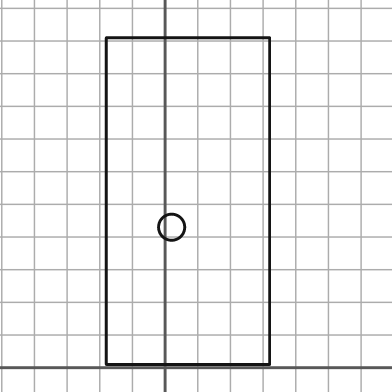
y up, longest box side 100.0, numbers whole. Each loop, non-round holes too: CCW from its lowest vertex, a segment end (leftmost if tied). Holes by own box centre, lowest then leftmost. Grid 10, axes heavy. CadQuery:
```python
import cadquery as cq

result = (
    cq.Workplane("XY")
    .moveTo(-18.0, 1.0)
    .lineTo(32.0, 1.0)
    .lineTo(32.0, 101.0)
    .lineTo(-18.0, 101.0)
    .close()
    .moveTo(2.0, 43.0)
    .circle(4.0)
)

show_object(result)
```